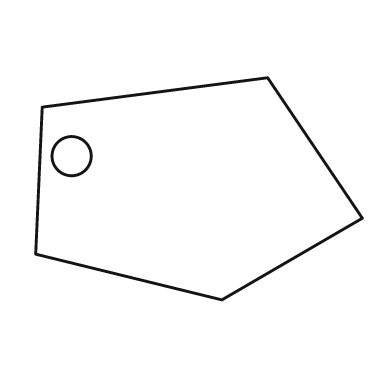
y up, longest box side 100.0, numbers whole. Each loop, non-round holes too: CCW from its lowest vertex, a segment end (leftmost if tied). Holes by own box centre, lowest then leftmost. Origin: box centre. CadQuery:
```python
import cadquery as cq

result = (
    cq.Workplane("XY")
    .moveTo(7.0, -34.0)
    .lineTo(50.0, -9.0)
    .lineTo(21.0, 34.0)
    .lineTo(-48.0, 25.0)
    .lineTo(-50.0, -20.0)
    .close()
    .moveTo(-39.0, 10.0)
    .circle(6.0)
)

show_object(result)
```